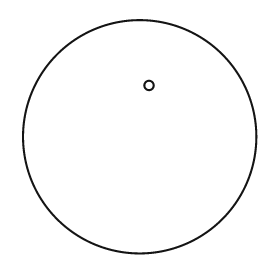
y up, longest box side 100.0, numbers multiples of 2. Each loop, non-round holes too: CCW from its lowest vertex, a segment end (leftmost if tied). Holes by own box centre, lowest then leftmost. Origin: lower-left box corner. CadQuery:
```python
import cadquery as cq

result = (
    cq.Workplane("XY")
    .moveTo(50.0, 50.0)
    .circle(50.0)
    .moveTo(54.0, 72.0)
    .circle(2.0)
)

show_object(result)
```